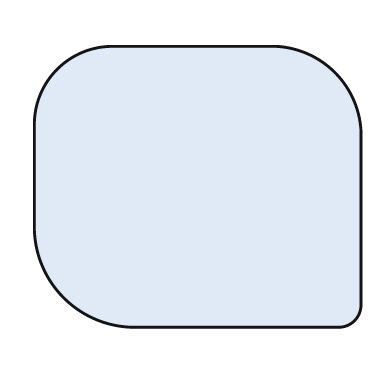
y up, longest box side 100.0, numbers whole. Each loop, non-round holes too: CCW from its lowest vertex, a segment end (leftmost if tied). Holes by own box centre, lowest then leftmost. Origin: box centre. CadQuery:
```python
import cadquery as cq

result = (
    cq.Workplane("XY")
    .moveTo(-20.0, -43.0)
    .lineTo(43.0, -43.0)
    .threePointArc((48.0, -41.0), (50.0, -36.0))
    .lineTo(50.0, 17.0)
    .threePointArc((42.0, 35.0), (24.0, 43.0))
    .lineTo(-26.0, 43.0)
    .threePointArc((-43.0, 36.0), (-50.0, 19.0))
    .lineTo(-50.0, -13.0)
    .threePointArc((-41.0, -34.0), (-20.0, -43.0))
    .close()
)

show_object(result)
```